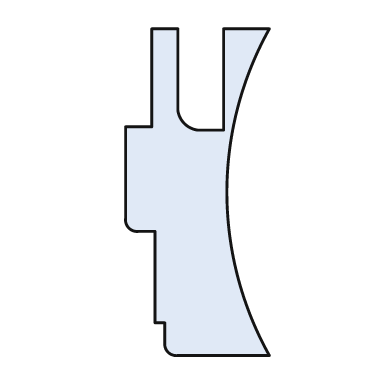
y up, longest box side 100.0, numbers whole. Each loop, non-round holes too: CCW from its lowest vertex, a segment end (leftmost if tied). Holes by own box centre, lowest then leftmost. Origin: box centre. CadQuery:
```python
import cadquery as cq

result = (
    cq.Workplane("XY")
    .moveTo(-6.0, -50.0)
    .lineTo(22.0, -50.0)
    .threePointArc((9.0, 0.0), (22.0, 50.0))
    .lineTo(8.0, 50.0)
    .lineTo(8.0, 19.0)
    .lineTo(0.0, 19.0)
    .threePointArc((-4.0, 21.0), (-6.0, 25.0))
    .lineTo(-6.0, 50.0)
    .lineTo(-14.0, 50.0)
    .lineTo(-14.0, 20.0)
    .lineTo(-22.0, 20.0)
    .lineTo(-22.0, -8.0)
    .threePointArc((-21.0, -11.0), (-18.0, -12.0))
    .lineTo(-13.0, -12.0)
    .lineTo(-13.0, -40.0)
    .lineTo(-10.0, -40.0)
    .lineTo(-10.0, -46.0)
    .threePointArc((-9.0, -49.0), (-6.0, -50.0))
    .close()
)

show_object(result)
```